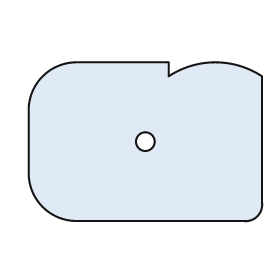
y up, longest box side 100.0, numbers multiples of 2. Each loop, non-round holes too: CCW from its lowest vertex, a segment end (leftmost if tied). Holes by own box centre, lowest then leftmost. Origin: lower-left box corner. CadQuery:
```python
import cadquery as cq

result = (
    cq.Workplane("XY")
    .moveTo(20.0, 0.0)
    .lineTo(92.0, 0.0)
    .threePointArc((98.0, 2.0), (100.0, 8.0))
    .lineTo(100.0, 62.0)
    .threePointArc((80.0, 68.0), (60.0, 62.0))
    .lineTo(60.0, 68.0)
    .lineTo(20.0, 68.0)
    .threePointArc((6.0, 62.0), (0.0, 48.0))
    .lineTo(0.0, 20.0)
    .threePointArc((6.0, 6.0), (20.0, 0.0))
    .close()
    .moveTo(50.0, 34.0)
    .circle(4.0)
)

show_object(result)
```